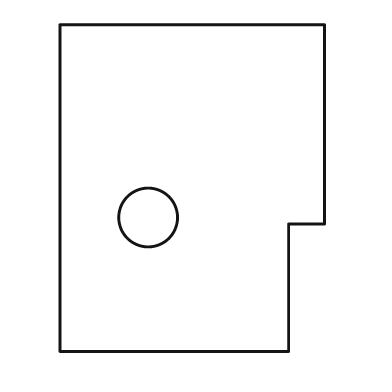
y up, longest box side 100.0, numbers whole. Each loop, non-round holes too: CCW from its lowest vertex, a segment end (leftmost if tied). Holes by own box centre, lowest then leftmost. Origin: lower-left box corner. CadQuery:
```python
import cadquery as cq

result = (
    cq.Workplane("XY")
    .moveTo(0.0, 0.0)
    .lineTo(70.0, 0.0)
    .lineTo(70.0, 39.0)
    .lineTo(81.0, 39.0)
    .lineTo(81.0, 100.0)
    .lineTo(0.0, 100.0)
    .close()
    .moveTo(27.0, 41.0)
    .circle(9.0)
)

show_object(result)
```